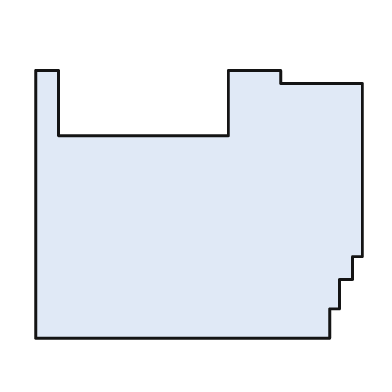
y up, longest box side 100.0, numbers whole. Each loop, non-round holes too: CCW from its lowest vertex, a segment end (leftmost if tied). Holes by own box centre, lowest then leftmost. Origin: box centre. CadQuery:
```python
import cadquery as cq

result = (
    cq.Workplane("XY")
    .moveTo(-50.0, -41.0)
    .lineTo(40.0, -41.0)
    .lineTo(40.0, -32.0)
    .lineTo(43.0, -32.0)
    .lineTo(43.0, -23.0)
    .lineTo(47.0, -23.0)
    .lineTo(47.0, -16.0)
    .lineTo(50.0, -16.0)
    .lineTo(50.0, 37.0)
    .lineTo(25.0, 37.0)
    .lineTo(25.0, 41.0)
    .lineTo(9.0, 41.0)
    .lineTo(9.0, 21.0)
    .lineTo(-43.0, 21.0)
    .lineTo(-43.0, 41.0)
    .lineTo(-50.0, 41.0)
    .close()
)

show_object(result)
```